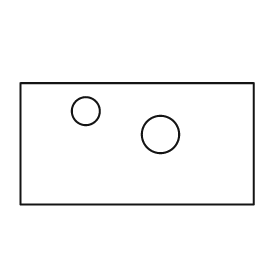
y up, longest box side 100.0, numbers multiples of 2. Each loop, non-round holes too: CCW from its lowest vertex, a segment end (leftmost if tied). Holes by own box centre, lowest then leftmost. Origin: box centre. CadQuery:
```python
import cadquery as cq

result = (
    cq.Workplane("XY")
    .moveTo(-50.0, -26.0)
    .lineTo(50.0, -26.0)
    .lineTo(50.0, 26.0)
    .lineTo(-50.0, 26.0)
    .close()
    .moveTo(10.0, 4.0)
    .circle(8.0)
    .moveTo(-22.0, 14.0)
    .circle(6.0)
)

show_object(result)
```